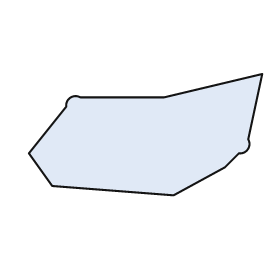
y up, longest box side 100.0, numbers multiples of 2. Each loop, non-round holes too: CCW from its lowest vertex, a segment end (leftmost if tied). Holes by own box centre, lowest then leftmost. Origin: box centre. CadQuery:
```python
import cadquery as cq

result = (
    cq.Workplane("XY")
    .moveTo(12.0, -26.0)
    .lineTo(34.0, -14.0)
    .lineTo(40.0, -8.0)
    .threePointArc((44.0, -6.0), (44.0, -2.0))
    .lineTo(50.0, 26.0)
    .lineTo(8.0, 16.0)
    .lineTo(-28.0, 16.0)
    .threePointArc((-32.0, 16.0), (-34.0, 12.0))
    .lineTo(-50.0, -8.0)
    .lineTo(-40.0, -22.0)
    .close()
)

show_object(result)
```